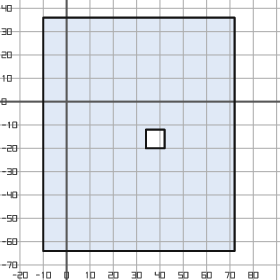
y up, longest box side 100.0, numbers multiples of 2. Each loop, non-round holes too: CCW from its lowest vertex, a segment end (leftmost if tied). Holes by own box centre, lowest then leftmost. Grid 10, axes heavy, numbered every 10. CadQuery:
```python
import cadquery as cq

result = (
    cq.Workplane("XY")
    .moveTo(-10.0, -64.0)
    .lineTo(72.0, -64.0)
    .lineTo(72.0, 36.0)
    .lineTo(-10.0, 36.0)
    .close()
    .moveTo(34.0, -20.0)
    .lineTo(42.0, -20.0)
    .lineTo(42.0, -12.0)
    .lineTo(34.0, -12.0)
    .close()
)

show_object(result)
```